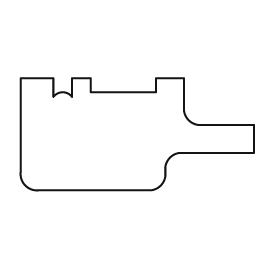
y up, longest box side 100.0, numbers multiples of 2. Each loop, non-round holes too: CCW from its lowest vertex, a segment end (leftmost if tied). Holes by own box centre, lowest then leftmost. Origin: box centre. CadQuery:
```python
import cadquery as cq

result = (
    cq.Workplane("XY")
    .moveTo(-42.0, -24.0)
    .lineTo(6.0, -24.0)
    .threePointArc((10.0, -22.0), (12.0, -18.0))
    .lineTo(12.0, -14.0)
    .threePointArc((14.0, -10.0), (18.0, -8.0))
    .lineTo(50.0, -8.0)
    .lineTo(50.0, 4.0)
    .lineTo(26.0, 4.0)
    .threePointArc((22.0, 6.0), (20.0, 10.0))
    .lineTo(20.0, 24.0)
    .lineTo(8.0, 24.0)
    .lineTo(8.0, 18.0)
    .lineTo(-20.0, 18.0)
    .lineTo(-20.0, 24.0)
    .lineTo(-28.0, 24.0)
    .lineTo(-28.0, 16.0)
    .threePointArc((-32.0, 18.0), (-36.0, 16.0))
    .lineTo(-36.0, 24.0)
    .lineTo(-50.0, 24.0)
    .lineTo(-50.0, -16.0)
    .threePointArc((-48.0, -22.0), (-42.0, -24.0))
    .close()
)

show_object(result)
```